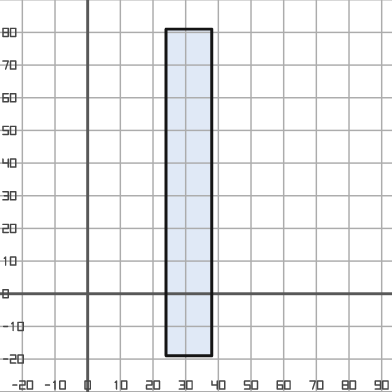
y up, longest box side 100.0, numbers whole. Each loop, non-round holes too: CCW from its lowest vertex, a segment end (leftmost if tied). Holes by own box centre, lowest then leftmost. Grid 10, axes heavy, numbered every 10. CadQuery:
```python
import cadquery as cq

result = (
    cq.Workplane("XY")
    .moveTo(24.0, -19.0)
    .lineTo(38.0, -19.0)
    .lineTo(38.0, 81.0)
    .lineTo(24.0, 81.0)
    .close()
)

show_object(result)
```